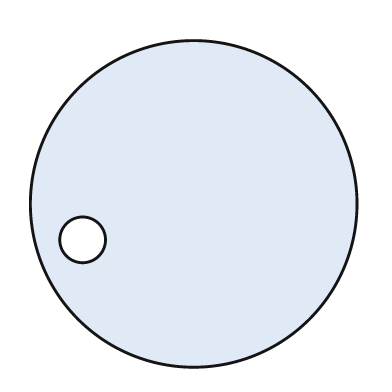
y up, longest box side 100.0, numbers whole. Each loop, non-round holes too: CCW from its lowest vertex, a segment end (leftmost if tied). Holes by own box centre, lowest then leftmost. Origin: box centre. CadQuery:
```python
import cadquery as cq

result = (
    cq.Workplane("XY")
    .moveTo(0.0, 0.0)
    .circle(50.0)
    .moveTo(-34.0, -11.0)
    .circle(7.0)
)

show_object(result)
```